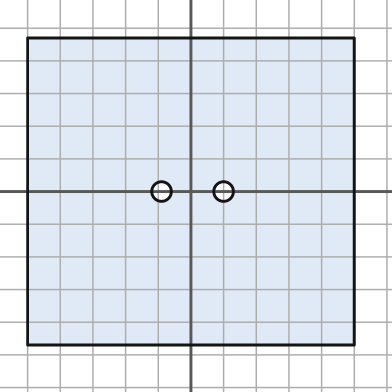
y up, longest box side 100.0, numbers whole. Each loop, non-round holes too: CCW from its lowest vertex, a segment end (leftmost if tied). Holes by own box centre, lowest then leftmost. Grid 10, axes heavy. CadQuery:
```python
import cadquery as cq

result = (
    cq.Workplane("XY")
    .moveTo(-50.0, -47.0)
    .lineTo(50.0, -47.0)
    .lineTo(50.0, 47.0)
    .lineTo(-50.0, 47.0)
    .close()
    .moveTo(-9.0, 0.0)
    .circle(3.0)
    .moveTo(10.0, 0.0)
    .circle(3.0)
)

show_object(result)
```